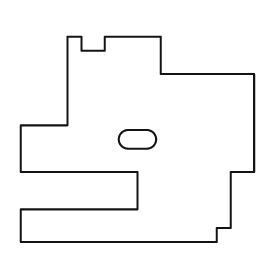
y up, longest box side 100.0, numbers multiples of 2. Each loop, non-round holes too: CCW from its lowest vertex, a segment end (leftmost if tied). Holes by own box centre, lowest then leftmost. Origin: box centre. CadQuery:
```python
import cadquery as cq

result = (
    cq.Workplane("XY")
    .moveTo(-50.0, -44.0)
    .lineTo(34.0, -44.0)
    .lineTo(34.0, -38.0)
    .lineTo(40.0, -38.0)
    .lineTo(40.0, -14.0)
    .lineTo(50.0, -14.0)
    .lineTo(50.0, 28.0)
    .lineTo(10.0, 28.0)
    .lineTo(10.0, 44.0)
    .lineTo(-14.0, 44.0)
    .lineTo(-14.0, 38.0)
    .lineTo(-24.0, 38.0)
    .lineTo(-24.0, 44.0)
    .lineTo(-30.0, 44.0)
    .lineTo(-30.0, 6.0)
    .lineTo(-50.0, 6.0)
    .lineTo(-50.0, -14.0)
    .lineTo(0.0, -14.0)
    .lineTo(0.0, -30.0)
    .lineTo(-50.0, -30.0)
    .close()
    .moveTo(-4.0, -4.0)
    .lineTo(4.0, -4.0)
    .threePointArc((8.0, 0.0), (4.0, 4.0))
    .lineTo(-4.0, 4.0)
    .threePointArc((-8.0, 0.0), (-4.0, -4.0))
    .close()
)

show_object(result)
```